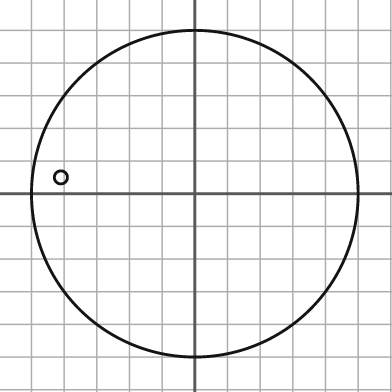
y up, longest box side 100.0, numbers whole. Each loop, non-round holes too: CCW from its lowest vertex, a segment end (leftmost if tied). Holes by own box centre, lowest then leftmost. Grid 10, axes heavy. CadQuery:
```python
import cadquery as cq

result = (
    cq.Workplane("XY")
    .moveTo(0.0, 0.0)
    .circle(50.0)
    .moveTo(-41.0, 5.0)
    .circle(2.0)
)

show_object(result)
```